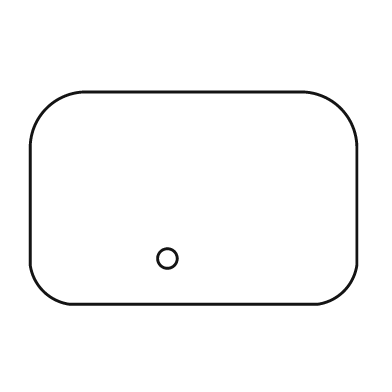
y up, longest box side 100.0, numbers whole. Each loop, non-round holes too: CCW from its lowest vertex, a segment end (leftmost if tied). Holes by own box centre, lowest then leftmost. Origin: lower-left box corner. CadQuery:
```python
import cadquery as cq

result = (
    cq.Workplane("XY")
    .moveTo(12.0, 0.0)
    .lineTo(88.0, 0.0)
    .threePointArc((96.0, 4.0), (100.0, 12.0))
    .lineTo(100.0, 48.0)
    .threePointArc((95.0, 60.0), (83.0, 65.0))
    .lineTo(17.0, 65.0)
    .threePointArc((5.0, 60.0), (0.0, 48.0))
    .lineTo(0.0, 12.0)
    .threePointArc((4.0, 4.0), (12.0, 0.0))
    .close()
    .moveTo(42.0, 14.0)
    .circle(3.0)
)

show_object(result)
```